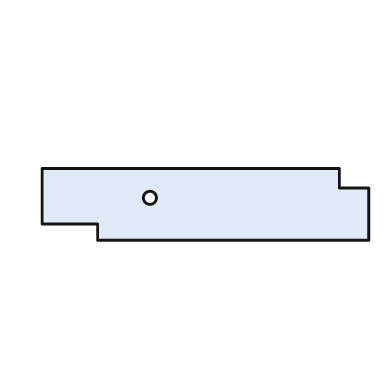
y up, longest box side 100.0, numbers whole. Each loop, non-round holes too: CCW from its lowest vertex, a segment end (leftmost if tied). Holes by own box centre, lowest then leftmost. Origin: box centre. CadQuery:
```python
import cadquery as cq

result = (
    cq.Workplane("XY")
    .moveTo(-33.0, -11.0)
    .lineTo(50.0, -11.0)
    .lineTo(50.0, 5.0)
    .lineTo(41.0, 5.0)
    .lineTo(41.0, 11.0)
    .lineTo(-50.0, 11.0)
    .lineTo(-50.0, -6.0)
    .lineTo(-33.0, -6.0)
    .close()
    .moveTo(-17.0, 2.0)
    .circle(2.0)
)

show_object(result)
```